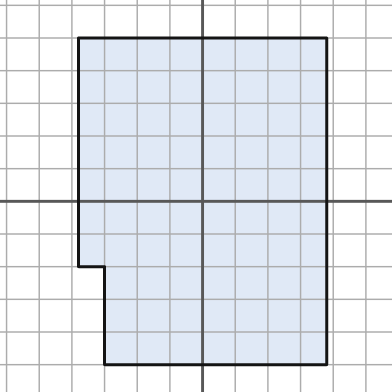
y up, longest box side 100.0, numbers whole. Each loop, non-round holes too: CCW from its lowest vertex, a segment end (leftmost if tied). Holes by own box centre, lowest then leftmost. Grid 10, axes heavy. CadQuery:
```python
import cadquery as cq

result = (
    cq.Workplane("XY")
    .moveTo(-30.0, -50.0)
    .lineTo(38.0, -50.0)
    .lineTo(38.0, 50.0)
    .lineTo(-38.0, 50.0)
    .lineTo(-38.0, -20.0)
    .lineTo(-30.0, -20.0)
    .close()
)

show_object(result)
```